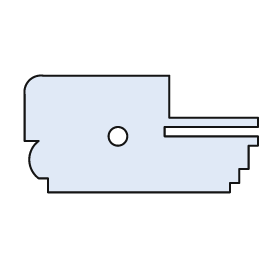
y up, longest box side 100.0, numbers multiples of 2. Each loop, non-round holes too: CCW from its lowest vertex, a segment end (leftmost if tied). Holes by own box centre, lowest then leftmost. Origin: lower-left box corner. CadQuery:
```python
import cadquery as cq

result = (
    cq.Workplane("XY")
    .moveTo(10.0, 0.0)
    .lineTo(88.0, 0.0)
    .lineTo(88.0, 4.0)
    .lineTo(92.0, 4.0)
    .lineTo(92.0, 10.0)
    .lineTo(96.0, 10.0)
    .lineTo(96.0, 20.0)
    .lineTo(100.0, 20.0)
    .lineTo(100.0, 24.0)
    .lineTo(60.0, 24.0)
    .lineTo(60.0, 28.0)
    .lineTo(100.0, 28.0)
    .lineTo(100.0, 32.0)
    .lineTo(62.0, 32.0)
    .lineTo(62.0, 50.0)
    .lineTo(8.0, 50.0)
    .threePointArc((2.0, 48.0), (0.0, 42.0))
    .lineTo(0.0, 22.0)
    .lineTo(6.0, 22.0)
    .threePointArc((2.0, 14.0), (6.0, 6.0))
    .lineTo(10.0, 6.0)
    .close()
    .moveTo(40.0, 24.0)
    .circle(4.0)
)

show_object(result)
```